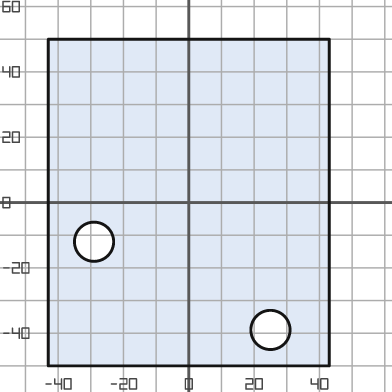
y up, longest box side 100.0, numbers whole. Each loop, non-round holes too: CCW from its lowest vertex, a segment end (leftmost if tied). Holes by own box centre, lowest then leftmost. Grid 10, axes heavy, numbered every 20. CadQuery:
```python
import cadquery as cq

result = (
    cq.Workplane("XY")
    .moveTo(-43.0, -50.0)
    .lineTo(43.0, -50.0)
    .lineTo(43.0, 50.0)
    .lineTo(-43.0, 50.0)
    .close()
    .moveTo(25.0, -39.0)
    .circle(6.0)
    .moveTo(-29.0, -12.0)
    .circle(6.0)
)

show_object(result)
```